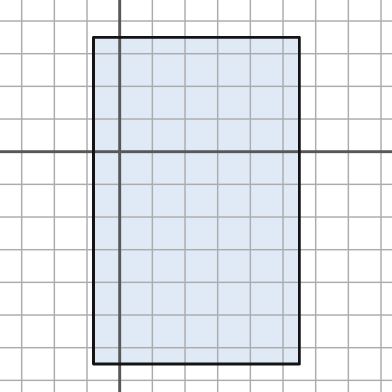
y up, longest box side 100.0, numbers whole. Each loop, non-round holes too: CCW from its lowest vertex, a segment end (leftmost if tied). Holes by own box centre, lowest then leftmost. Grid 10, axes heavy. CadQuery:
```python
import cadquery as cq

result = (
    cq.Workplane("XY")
    .moveTo(-8.0, -65.0)
    .lineTo(55.0, -65.0)
    .lineTo(55.0, 35.0)
    .lineTo(-8.0, 35.0)
    .close()
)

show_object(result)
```